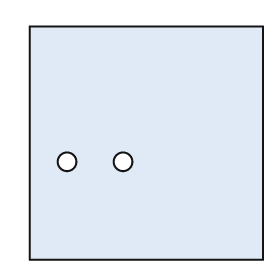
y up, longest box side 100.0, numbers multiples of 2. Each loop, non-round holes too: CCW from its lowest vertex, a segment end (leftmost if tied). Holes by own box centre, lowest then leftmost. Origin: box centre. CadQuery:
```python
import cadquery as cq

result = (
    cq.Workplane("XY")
    .moveTo(-50.0, -50.0)
    .lineTo(50.0, -50.0)
    .lineTo(50.0, 50.0)
    .lineTo(-50.0, 50.0)
    .close()
    .moveTo(-34.0, -8.0)
    .circle(4.0)
    .moveTo(-10.0, -8.0)
    .circle(4.0)
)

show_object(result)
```